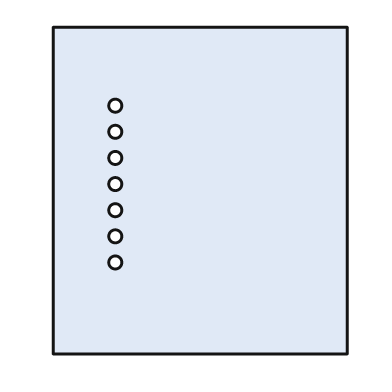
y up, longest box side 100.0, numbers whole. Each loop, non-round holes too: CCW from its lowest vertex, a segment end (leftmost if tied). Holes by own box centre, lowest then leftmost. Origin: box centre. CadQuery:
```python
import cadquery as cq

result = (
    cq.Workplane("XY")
    .moveTo(-45.0, -50.0)
    .lineTo(45.0, -50.0)
    .lineTo(45.0, 50.0)
    .lineTo(-45.0, 50.0)
    .close()
    .moveTo(-26.0, -22.0)
    .circle(2.0)
    .moveTo(-26.0, -14.0)
    .circle(2.0)
    .moveTo(-26.0, -6.0)
    .circle(2.0)
    .moveTo(-26.0, 2.0)
    .circle(2.0)
    .moveTo(-26.0, 10.0)
    .circle(2.0)
    .moveTo(-26.0, 18.0)
    .circle(2.0)
    .moveTo(-26.0, 26.0)
    .circle(2.0)
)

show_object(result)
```